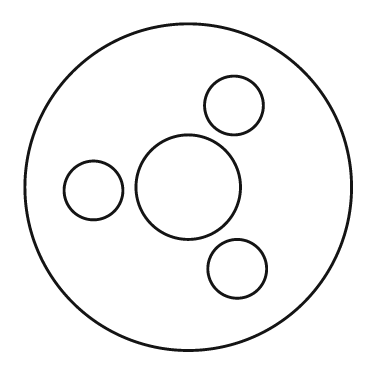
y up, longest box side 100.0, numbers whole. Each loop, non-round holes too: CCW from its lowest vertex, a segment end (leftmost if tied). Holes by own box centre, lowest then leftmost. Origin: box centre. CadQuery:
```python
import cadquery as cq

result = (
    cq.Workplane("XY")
    .moveTo(0.0, 0.0)
    .circle(50.0)
    .moveTo(15.0, -25.0)
    .circle(9.0)
    .moveTo(-29.0, -1.0)
    .circle(9.0)
    .moveTo(0.0, 0.0)
    .circle(16.0)
    .moveTo(14.0, 25.0)
    .circle(9.0)
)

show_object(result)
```